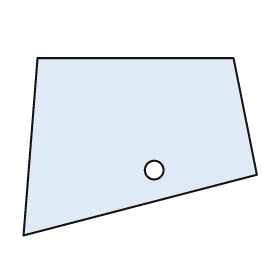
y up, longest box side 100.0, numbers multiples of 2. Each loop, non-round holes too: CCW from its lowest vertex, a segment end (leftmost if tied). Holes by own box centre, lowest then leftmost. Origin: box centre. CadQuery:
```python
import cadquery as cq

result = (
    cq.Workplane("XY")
    .moveTo(-50.0, -38.0)
    .lineTo(50.0, -12.0)
    .lineTo(40.0, 38.0)
    .lineTo(-44.0, 38.0)
    .close()
    .moveTo(6.0, -10.0)
    .circle(4.0)
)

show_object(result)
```